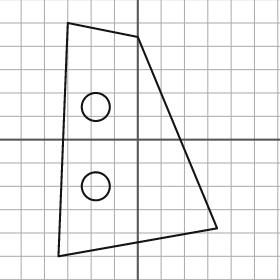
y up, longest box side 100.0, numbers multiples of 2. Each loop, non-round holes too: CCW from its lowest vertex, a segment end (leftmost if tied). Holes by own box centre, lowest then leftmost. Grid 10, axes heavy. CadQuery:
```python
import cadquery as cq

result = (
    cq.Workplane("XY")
    .moveTo(-34.0, -50.0)
    .lineTo(34.0, -38.0)
    .lineTo(0.0, 44.0)
    .lineTo(-30.0, 50.0)
    .close()
    .moveTo(-18.0, -20.0)
    .circle(6.0)
    .moveTo(-18.0, 14.0)
    .circle(6.0)
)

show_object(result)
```